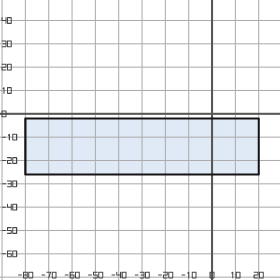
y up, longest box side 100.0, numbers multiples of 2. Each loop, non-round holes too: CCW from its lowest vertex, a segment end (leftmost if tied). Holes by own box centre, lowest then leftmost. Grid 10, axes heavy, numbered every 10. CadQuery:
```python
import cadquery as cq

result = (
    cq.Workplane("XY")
    .moveTo(-80.0, -26.0)
    .lineTo(20.0, -26.0)
    .lineTo(20.0, -2.0)
    .lineTo(-80.0, -2.0)
    .close()
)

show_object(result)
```